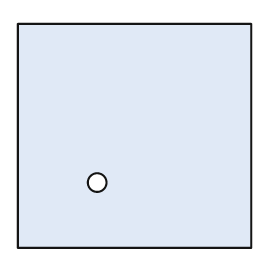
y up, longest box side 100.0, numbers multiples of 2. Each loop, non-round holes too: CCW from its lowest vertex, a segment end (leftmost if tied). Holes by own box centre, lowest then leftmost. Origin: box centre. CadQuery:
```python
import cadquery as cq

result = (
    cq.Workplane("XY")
    .moveTo(-50.0, -48.0)
    .lineTo(50.0, -48.0)
    .lineTo(50.0, 48.0)
    .lineTo(-50.0, 48.0)
    .close()
    .moveTo(-16.0, -20.0)
    .circle(4.0)
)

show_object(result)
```